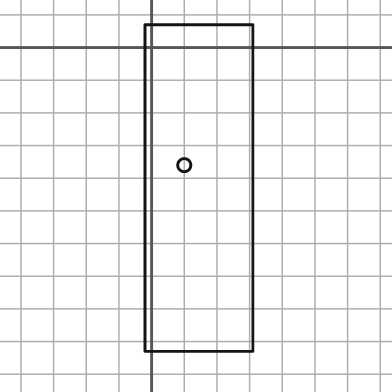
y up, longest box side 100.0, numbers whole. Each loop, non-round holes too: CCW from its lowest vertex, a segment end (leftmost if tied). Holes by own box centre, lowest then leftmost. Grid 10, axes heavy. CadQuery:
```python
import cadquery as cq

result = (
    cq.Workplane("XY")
    .moveTo(-2.0, -93.0)
    .lineTo(31.0, -93.0)
    .lineTo(31.0, 7.0)
    .lineTo(-2.0, 7.0)
    .close()
    .moveTo(10.0, -36.0)
    .circle(2.0)
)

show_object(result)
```